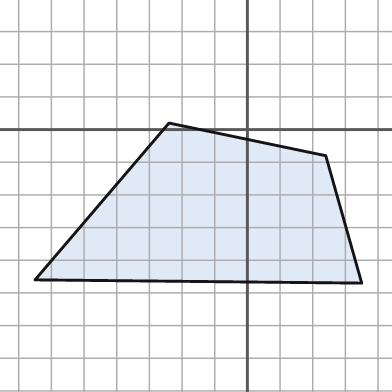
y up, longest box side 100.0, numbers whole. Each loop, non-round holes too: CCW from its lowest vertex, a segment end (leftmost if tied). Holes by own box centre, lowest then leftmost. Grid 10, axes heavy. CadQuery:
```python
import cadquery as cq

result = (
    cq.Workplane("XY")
    .moveTo(35.0, -47.0)
    .lineTo(24.0, -8.0)
    .lineTo(-24.0, 2.0)
    .lineTo(-65.0, -46.0)
    .close()
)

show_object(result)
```